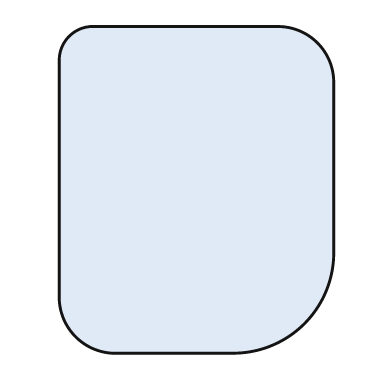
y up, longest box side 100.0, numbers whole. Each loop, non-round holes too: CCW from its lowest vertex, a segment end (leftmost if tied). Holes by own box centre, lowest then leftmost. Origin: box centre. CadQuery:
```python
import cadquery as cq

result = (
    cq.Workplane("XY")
    .moveTo(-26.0, -50.0)
    .lineTo(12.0, -50.0)
    .threePointArc((33.0, -41.0), (42.0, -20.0))
    .lineTo(42.0, 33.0)
    .threePointArc((37.0, 45.0), (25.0, 50.0))
    .lineTo(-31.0, 50.0)
    .threePointArc((-39.0, 47.0), (-42.0, 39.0))
    .lineTo(-42.0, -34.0)
    .threePointArc((-37.0, -45.0), (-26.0, -50.0))
    .close()
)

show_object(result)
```